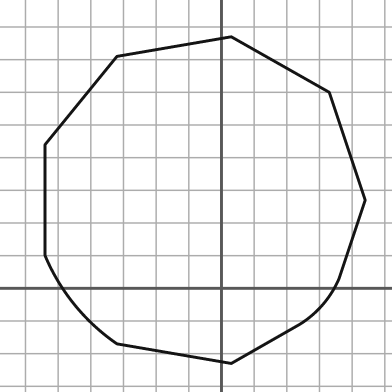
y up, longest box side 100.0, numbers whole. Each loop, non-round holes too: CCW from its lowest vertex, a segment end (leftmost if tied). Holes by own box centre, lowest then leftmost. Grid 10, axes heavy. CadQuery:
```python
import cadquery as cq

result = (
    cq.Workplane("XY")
    .moveTo(3.0, -23.0)
    .lineTo(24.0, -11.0)
    .threePointArc((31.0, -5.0), (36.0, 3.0))
    .lineTo(44.0, 27.0)
    .lineTo(33.0, 60.0)
    .lineTo(3.0, 77.0)
    .lineTo(-32.0, 71.0)
    .lineTo(-54.0, 44.0)
    .lineTo(-54.0, 10.0)
    .threePointArc((-45.0, -5.0), (-32.0, -17.0))
    .close()
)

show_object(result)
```